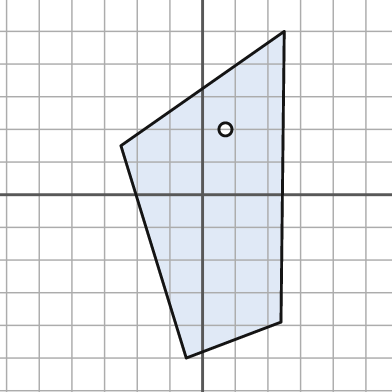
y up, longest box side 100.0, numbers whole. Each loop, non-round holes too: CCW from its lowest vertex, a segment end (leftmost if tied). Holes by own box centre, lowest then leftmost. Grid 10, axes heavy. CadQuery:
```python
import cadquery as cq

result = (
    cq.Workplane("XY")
    .moveTo(-5.0, -50.0)
    .lineTo(24.0, -39.0)
    .lineTo(25.0, 50.0)
    .lineTo(-25.0, 15.0)
    .close()
    .moveTo(7.0, 20.0)
    .circle(2.0)
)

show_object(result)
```